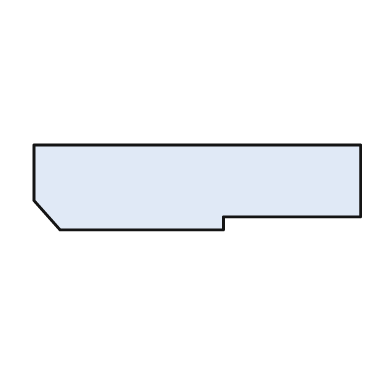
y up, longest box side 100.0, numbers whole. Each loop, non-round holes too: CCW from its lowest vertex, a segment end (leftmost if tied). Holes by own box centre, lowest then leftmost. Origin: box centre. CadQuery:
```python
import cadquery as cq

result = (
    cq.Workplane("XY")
    .moveTo(-42.0, -13.0)
    .lineTo(8.0, -13.0)
    .lineTo(8.0, -9.0)
    .lineTo(50.0, -9.0)
    .lineTo(50.0, 13.0)
    .lineTo(-50.0, 13.0)
    .lineTo(-50.0, -4.0)
    .close()
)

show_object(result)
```